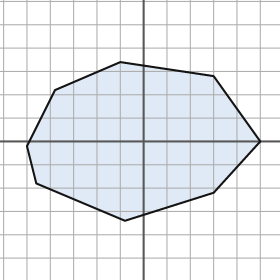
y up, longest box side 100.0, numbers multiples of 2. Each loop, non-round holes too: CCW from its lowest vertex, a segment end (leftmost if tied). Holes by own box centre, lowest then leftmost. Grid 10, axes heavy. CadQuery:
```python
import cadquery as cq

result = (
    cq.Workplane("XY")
    .moveTo(-8.0, -34.0)
    .lineTo(30.0, -22.0)
    .lineTo(50.0, 0.0)
    .lineTo(30.0, 28.0)
    .lineTo(-10.0, 34.0)
    .lineTo(-38.0, 22.0)
    .lineTo(-50.0, -2.0)
    .lineTo(-46.0, -18.0)
    .close()
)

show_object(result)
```